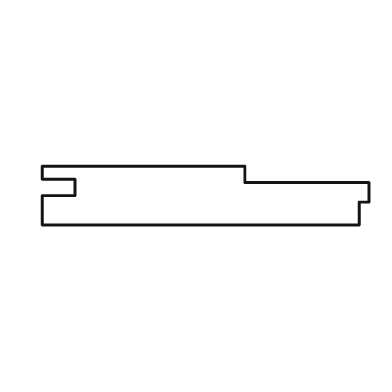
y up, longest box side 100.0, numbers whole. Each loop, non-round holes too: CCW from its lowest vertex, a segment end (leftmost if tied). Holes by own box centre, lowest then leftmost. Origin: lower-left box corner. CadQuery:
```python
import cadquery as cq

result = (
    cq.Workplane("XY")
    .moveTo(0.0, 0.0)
    .lineTo(97.0, 0.0)
    .lineTo(97.0, 7.0)
    .lineTo(100.0, 7.0)
    .lineTo(100.0, 13.0)
    .lineTo(62.0, 13.0)
    .lineTo(62.0, 18.0)
    .lineTo(0.0, 18.0)
    .lineTo(0.0, 14.0)
    .lineTo(10.0, 14.0)
    .lineTo(10.0, 9.0)
    .lineTo(0.0, 9.0)
    .close()
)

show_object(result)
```